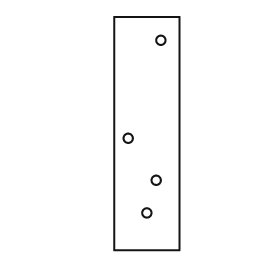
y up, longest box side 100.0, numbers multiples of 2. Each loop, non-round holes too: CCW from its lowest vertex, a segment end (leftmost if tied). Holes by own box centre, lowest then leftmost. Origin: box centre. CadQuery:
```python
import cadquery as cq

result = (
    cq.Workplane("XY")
    .moveTo(-14.0, -50.0)
    .lineTo(14.0, -50.0)
    .lineTo(14.0, 50.0)
    .lineTo(-14.0, 50.0)
    .close()
    .moveTo(0.0, -34.0)
    .circle(2.0)
    .moveTo(4.0, -20.0)
    .circle(2.0)
    .moveTo(-8.0, -2.0)
    .circle(2.0)
    .moveTo(6.0, 40.0)
    .circle(2.0)
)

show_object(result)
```